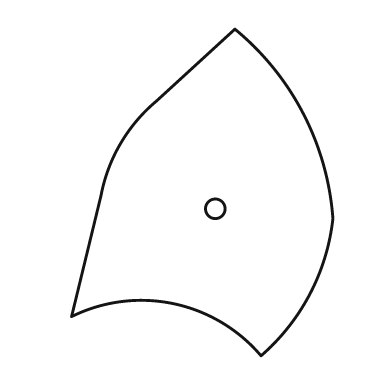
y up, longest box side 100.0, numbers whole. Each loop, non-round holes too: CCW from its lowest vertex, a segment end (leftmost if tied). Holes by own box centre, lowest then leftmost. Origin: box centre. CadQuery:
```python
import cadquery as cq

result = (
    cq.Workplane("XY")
    .moveTo(18.0, -50.0)
    .threePointArc((33.0, -31.0), (40.0, -8.0))
    .threePointArc((31.0, 24.0), (10.0, 50.0))
    .lineTo(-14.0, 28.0)
    .threePointArc((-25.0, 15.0), (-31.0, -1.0))
    .lineTo(-40.0, -38.0)
    .threePointArc((-9.0, -34.0), (18.0, -50.0))
    .close()
    .moveTo(4.0, -5.0)
    .circle(3.0)
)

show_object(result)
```